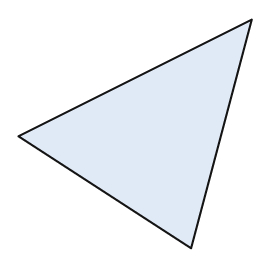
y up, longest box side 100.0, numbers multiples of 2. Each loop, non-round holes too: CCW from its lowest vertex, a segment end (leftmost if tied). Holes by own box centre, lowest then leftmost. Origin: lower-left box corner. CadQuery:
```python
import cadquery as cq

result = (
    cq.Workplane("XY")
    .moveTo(74.0, 0.0)
    .lineTo(100.0, 98.0)
    .lineTo(0.0, 48.0)
    .close()
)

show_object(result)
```